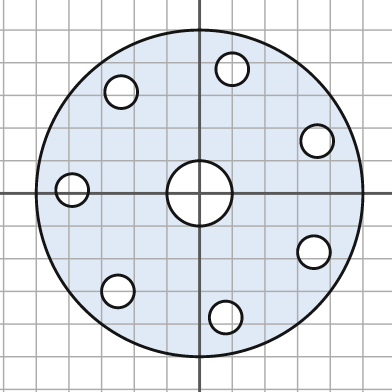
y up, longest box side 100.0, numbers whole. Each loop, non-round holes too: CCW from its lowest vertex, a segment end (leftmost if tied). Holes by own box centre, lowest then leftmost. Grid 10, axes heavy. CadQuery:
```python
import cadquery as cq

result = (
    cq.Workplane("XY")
    .moveTo(0.0, 0.0)
    .circle(50.0)
    .moveTo(8.0, -38.0)
    .circle(5.0)
    .moveTo(-25.0, -30.0)
    .circle(5.0)
    .moveTo(35.0, -18.0)
    .circle(5.0)
    .moveTo(0.0, 0.0)
    .circle(10.0)
    .moveTo(-39.0, 1.0)
    .circle(5.0)
    .moveTo(36.0, 16.0)
    .circle(5.0)
    .moveTo(-24.0, 31.0)
    .circle(5.0)
    .moveTo(10.0, 38.0)
    .circle(5.0)
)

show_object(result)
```